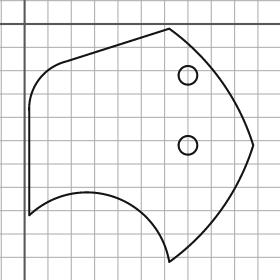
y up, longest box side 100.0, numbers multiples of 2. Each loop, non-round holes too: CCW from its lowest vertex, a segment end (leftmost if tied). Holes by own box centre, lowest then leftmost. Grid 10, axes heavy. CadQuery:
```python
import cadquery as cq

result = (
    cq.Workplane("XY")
    .moveTo(62.0, -102.0)
    .threePointArc((84.0, -80.0), (98.0, -52.0))
    .threePointArc((84.0, -24.0), (62.0, -2.0))
    .lineTo(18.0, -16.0)
    .threePointArc((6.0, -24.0), (2.0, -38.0))
    .lineTo(2.0, -82.0)
    .threePointArc((38.0, -74.0), (62.0, -102.0))
    .close()
    .moveTo(70.0, -52.0)
    .circle(4.0)
    .moveTo(70.0, -22.0)
    .circle(4.0)
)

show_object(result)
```